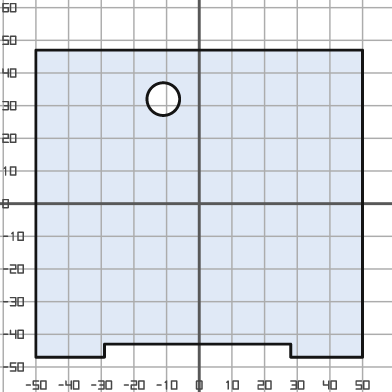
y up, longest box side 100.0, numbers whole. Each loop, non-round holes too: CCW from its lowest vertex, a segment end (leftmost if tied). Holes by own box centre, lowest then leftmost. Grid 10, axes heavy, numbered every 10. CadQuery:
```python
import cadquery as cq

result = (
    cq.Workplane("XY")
    .moveTo(-50.0, -47.0)
    .lineTo(-29.0, -47.0)
    .lineTo(-29.0, -43.0)
    .lineTo(28.0, -43.0)
    .lineTo(28.0, -47.0)
    .lineTo(50.0, -47.0)
    .lineTo(50.0, 47.0)
    .lineTo(-50.0, 47.0)
    .close()
    .moveTo(-11.0, 32.0)
    .circle(5.0)
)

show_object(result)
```